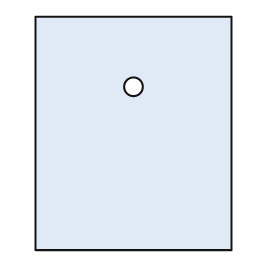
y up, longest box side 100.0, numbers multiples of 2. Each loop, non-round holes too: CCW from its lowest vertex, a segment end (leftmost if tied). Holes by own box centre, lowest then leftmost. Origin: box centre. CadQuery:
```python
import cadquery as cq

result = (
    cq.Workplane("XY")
    .moveTo(-42.0, -50.0)
    .lineTo(42.0, -50.0)
    .lineTo(42.0, 50.0)
    .lineTo(-42.0, 50.0)
    .close()
    .moveTo(0.0, 20.0)
    .circle(4.0)
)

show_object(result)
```